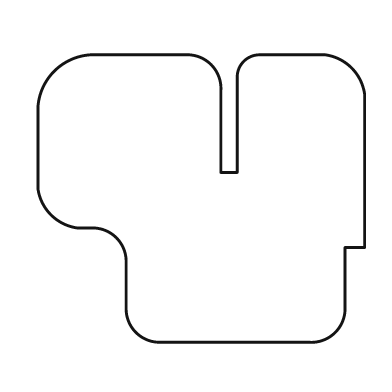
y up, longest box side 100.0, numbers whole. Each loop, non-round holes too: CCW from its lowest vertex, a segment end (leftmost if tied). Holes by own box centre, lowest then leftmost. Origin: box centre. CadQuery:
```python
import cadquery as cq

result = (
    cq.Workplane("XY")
    .moveTo(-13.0, -44.0)
    .lineTo(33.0, -44.0)
    .threePointArc((41.0, -41.0), (44.0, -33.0))
    .lineTo(44.0, -15.0)
    .lineTo(50.0, -15.0)
    .lineTo(50.0, 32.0)
    .threePointArc((46.0, 40.0), (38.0, 44.0))
    .lineTo(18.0, 44.0)
    .threePointArc((13.0, 42.0), (11.0, 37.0))
    .lineTo(11.0, 8.0)
    .lineTo(6.0, 8.0)
    .lineTo(6.0, 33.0)
    .threePointArc((3.0, 41.0), (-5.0, 44.0))
    .lineTo(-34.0, 44.0)
    .threePointArc((-45.0, 39.0), (-50.0, 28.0))
    .lineTo(-50.0, 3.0)
    .threePointArc((-46.0, -5.0), (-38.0, -9.0))
    .lineTo(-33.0, -9.0)
    .threePointArc((-26.0, -12.0), (-23.0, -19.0))
    .lineTo(-23.0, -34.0)
    .threePointArc((-20.0, -41.0), (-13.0, -44.0))
    .close()
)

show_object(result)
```